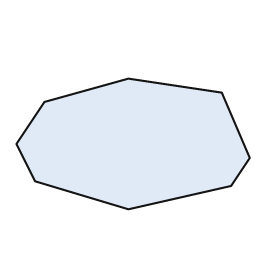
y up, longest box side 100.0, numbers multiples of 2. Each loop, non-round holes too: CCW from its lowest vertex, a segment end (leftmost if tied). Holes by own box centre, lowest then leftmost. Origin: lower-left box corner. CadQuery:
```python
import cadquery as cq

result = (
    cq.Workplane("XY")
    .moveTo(48.0, 0.0)
    .lineTo(92.0, 10.0)
    .lineTo(100.0, 22.0)
    .lineTo(88.0, 50.0)
    .lineTo(48.0, 56.0)
    .lineTo(12.0, 46.0)
    .lineTo(0.0, 28.0)
    .lineTo(8.0, 12.0)
    .close()
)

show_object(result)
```